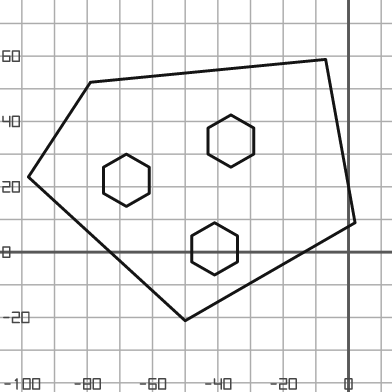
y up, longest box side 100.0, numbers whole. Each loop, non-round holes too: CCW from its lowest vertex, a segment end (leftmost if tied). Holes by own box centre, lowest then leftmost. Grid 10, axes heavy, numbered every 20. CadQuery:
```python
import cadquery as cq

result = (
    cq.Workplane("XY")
    .moveTo(-50.0, -21.0)
    .lineTo(2.0, 9.0)
    .lineTo(-7.0, 59.0)
    .lineTo(-79.0, 52.0)
    .lineTo(-98.0, 23.0)
    .close()
    .moveTo(-41.0, -7.0)
    .lineTo(-34.0, -3.0)
    .lineTo(-34.0, 5.0)
    .lineTo(-41.0, 9.0)
    .lineTo(-48.0, 5.0)
    .lineTo(-48.0, -3.0)
    .close()
    .moveTo(-68.0, 14.0)
    .lineTo(-61.0, 18.0)
    .lineTo(-61.0, 26.0)
    .lineTo(-68.0, 30.0)
    .lineTo(-75.0, 26.0)
    .lineTo(-75.0, 18.0)
    .close()
    .moveTo(-36.0, 26.0)
    .lineTo(-29.0, 30.0)
    .lineTo(-29.0, 38.0)
    .lineTo(-36.0, 42.0)
    .lineTo(-43.0, 38.0)
    .lineTo(-43.0, 30.0)
    .close()
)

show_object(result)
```